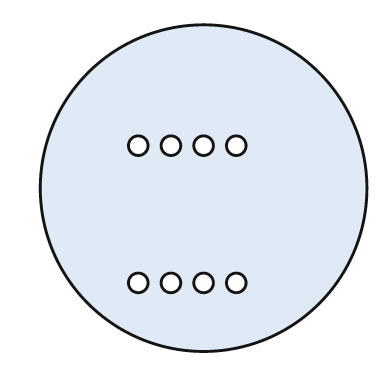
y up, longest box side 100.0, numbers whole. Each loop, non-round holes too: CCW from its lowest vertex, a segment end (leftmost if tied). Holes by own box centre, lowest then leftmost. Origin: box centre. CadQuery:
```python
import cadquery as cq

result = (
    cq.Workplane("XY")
    .moveTo(0.0, 0.0)
    .circle(50.0)
    .moveTo(-20.0, -29.0)
    .circle(3.0)
    .moveTo(-10.0, -29.0)
    .circle(3.0)
    .moveTo(0.0, -29.0)
    .circle(3.0)
    .moveTo(10.0, -29.0)
    .circle(3.0)
    .moveTo(-20.0, 13.0)
    .circle(3.0)
    .moveTo(-10.0, 13.0)
    .circle(3.0)
    .moveTo(0.0, 13.0)
    .circle(3.0)
    .moveTo(10.0, 13.0)
    .circle(3.0)
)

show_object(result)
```